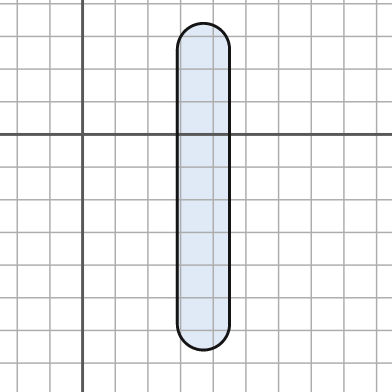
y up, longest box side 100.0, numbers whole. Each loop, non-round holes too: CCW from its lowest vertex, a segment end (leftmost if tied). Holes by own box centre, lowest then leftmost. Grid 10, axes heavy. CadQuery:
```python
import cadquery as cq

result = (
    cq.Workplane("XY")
    .moveTo(29.0, -58.0)
    .threePointArc((37.0, -66.0), (45.0, -58.0))
    .lineTo(45.0, 26.0)
    .threePointArc((37.0, 34.0), (29.0, 26.0))
    .close()
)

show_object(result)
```